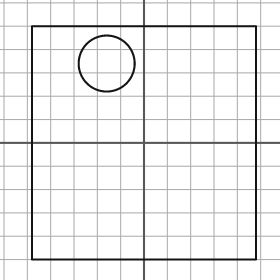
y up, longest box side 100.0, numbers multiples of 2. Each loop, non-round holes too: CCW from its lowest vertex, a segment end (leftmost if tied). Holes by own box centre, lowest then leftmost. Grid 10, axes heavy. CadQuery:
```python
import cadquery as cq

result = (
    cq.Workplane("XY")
    .moveTo(-48.0, -50.0)
    .lineTo(48.0, -50.0)
    .lineTo(48.0, 50.0)
    .lineTo(-48.0, 50.0)
    .close()
    .moveTo(-16.0, 34.0)
    .circle(12.0)
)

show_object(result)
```